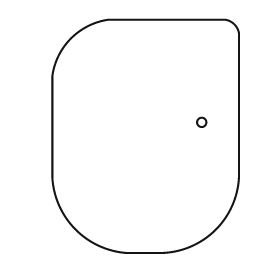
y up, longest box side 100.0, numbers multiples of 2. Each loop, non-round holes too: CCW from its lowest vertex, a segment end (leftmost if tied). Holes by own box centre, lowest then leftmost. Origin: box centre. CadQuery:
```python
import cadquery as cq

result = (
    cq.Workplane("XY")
    .moveTo(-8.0, -50.0)
    .lineTo(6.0, -50.0)
    .threePointArc((30.0, -40.0), (40.0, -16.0))
    .lineTo(40.0, 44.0)
    .threePointArc((38.0, 48.0), (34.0, 50.0))
    .lineTo(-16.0, 50.0)
    .threePointArc((-32.0, 42.0), (-40.0, 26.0))
    .lineTo(-40.0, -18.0)
    .threePointArc((-30.0, -40.0), (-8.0, -50.0))
    .close()
    .moveTo(24.0, 6.0)
    .circle(2.0)
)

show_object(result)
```